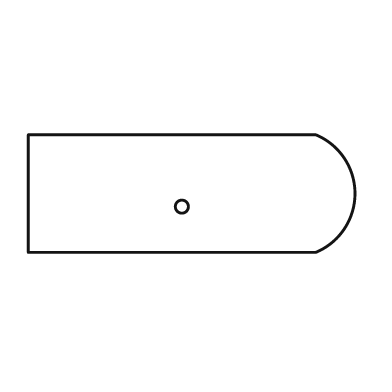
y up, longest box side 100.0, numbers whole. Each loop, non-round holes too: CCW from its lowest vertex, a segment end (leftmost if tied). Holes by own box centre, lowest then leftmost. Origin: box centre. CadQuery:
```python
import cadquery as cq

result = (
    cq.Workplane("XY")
    .moveTo(-50.0, -18.0)
    .lineTo(38.0, -18.0)
    .threePointArc((50.0, 0.0), (38.0, 18.0))
    .lineTo(-50.0, 18.0)
    .close()
    .moveTo(-3.0, -4.0)
    .circle(2.0)
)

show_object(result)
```